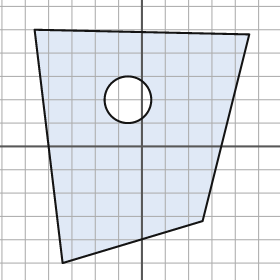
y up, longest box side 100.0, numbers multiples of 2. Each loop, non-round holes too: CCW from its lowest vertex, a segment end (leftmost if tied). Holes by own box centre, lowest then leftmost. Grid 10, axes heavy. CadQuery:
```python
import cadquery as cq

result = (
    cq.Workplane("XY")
    .moveTo(-34.0, -50.0)
    .lineTo(26.0, -32.0)
    .lineTo(46.0, 48.0)
    .lineTo(-46.0, 50.0)
    .close()
    .moveTo(-6.0, 20.0)
    .circle(10.0)
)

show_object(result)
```